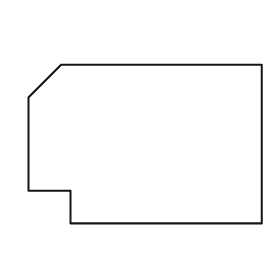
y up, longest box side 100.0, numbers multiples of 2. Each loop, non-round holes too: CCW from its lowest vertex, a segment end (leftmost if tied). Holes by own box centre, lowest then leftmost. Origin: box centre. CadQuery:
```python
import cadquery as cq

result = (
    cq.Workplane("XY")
    .moveTo(-32.0, -34.0)
    .lineTo(50.0, -34.0)
    .lineTo(50.0, 34.0)
    .lineTo(-36.0, 34.0)
    .lineTo(-50.0, 20.0)
    .lineTo(-50.0, -20.0)
    .lineTo(-32.0, -20.0)
    .close()
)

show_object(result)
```